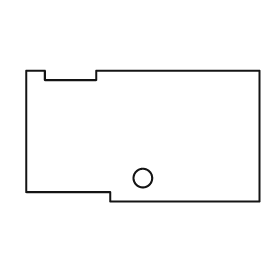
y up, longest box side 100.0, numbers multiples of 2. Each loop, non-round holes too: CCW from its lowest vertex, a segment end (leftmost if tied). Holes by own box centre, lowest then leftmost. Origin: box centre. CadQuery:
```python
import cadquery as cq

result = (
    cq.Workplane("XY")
    .moveTo(-14.0, -28.0)
    .lineTo(50.0, -28.0)
    .lineTo(50.0, 28.0)
    .lineTo(-20.0, 28.0)
    .lineTo(-20.0, 24.0)
    .lineTo(-42.0, 24.0)
    .lineTo(-42.0, 28.0)
    .lineTo(-50.0, 28.0)
    .lineTo(-50.0, -24.0)
    .lineTo(-14.0, -24.0)
    .close()
    .moveTo(0.0, -18.0)
    .circle(4.0)
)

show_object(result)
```